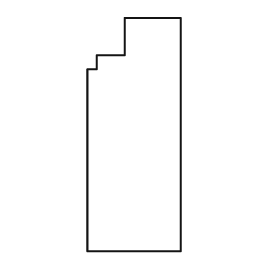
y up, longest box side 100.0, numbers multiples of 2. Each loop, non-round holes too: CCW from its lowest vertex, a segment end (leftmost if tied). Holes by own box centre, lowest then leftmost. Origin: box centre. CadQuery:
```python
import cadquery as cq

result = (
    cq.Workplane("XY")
    .moveTo(-20.0, -50.0)
    .lineTo(20.0, -50.0)
    .lineTo(20.0, 50.0)
    .lineTo(-4.0, 50.0)
    .lineTo(-4.0, 34.0)
    .lineTo(-16.0, 34.0)
    .lineTo(-16.0, 28.0)
    .lineTo(-20.0, 28.0)
    .close()
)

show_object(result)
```